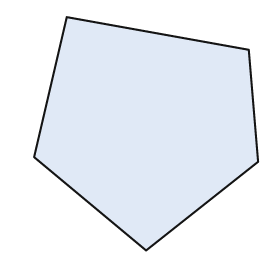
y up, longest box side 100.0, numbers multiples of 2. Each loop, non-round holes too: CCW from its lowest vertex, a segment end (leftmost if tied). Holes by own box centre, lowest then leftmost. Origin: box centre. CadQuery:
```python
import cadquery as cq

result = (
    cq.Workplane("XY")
    .moveTo(0.0, -50.0)
    .lineTo(48.0, -12.0)
    .lineTo(44.0, 36.0)
    .lineTo(-34.0, 50.0)
    .lineTo(-48.0, -10.0)
    .close()
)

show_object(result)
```